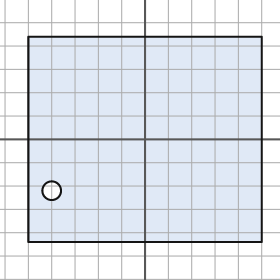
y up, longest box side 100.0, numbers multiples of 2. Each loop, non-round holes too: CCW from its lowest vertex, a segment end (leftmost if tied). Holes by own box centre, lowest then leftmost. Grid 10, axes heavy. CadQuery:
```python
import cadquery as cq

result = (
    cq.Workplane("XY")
    .moveTo(-50.0, -44.0)
    .lineTo(50.0, -44.0)
    .lineTo(50.0, 44.0)
    .lineTo(-50.0, 44.0)
    .close()
    .moveTo(-40.0, -22.0)
    .circle(4.0)
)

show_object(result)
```